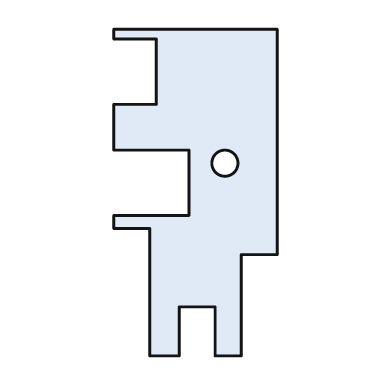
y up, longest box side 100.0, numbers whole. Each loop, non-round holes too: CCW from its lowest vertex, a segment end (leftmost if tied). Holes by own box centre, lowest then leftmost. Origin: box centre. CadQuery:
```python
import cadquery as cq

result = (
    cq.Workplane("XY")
    .moveTo(-14.0, -50.0)
    .lineTo(-5.0, -50.0)
    .lineTo(-5.0, -35.0)
    .lineTo(6.0, -35.0)
    .lineTo(6.0, -50.0)
    .lineTo(14.0, -50.0)
    .lineTo(14.0, -19.0)
    .lineTo(25.0, -19.0)
    .lineTo(25.0, 50.0)
    .lineTo(-25.0, 50.0)
    .lineTo(-25.0, 47.0)
    .lineTo(-12.0, 47.0)
    .lineTo(-12.0, 27.0)
    .lineTo(-25.0, 27.0)
    .lineTo(-25.0, 13.0)
    .lineTo(-2.0, 13.0)
    .lineTo(-2.0, -7.0)
    .lineTo(-25.0, -7.0)
    .lineTo(-25.0, -11.0)
    .lineTo(-14.0, -11.0)
    .close()
    .moveTo(9.0, 9.0)
    .circle(4.0)
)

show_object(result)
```